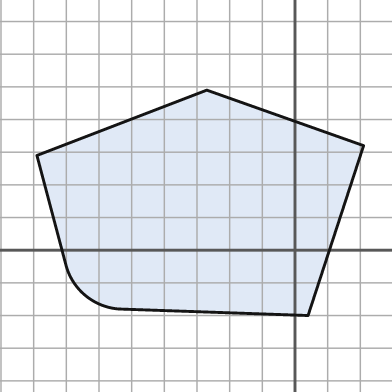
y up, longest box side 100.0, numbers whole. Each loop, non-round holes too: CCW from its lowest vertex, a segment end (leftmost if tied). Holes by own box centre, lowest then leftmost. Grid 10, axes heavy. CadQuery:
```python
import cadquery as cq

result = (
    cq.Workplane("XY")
    .moveTo(4.0, -20.0)
    .lineTo(21.0, 32.0)
    .lineTo(-27.0, 49.0)
    .lineTo(-79.0, 29.0)
    .lineTo(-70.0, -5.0)
    .threePointArc((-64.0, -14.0), (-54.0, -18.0))
    .close()
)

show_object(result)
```